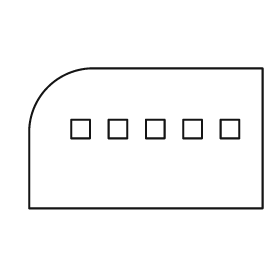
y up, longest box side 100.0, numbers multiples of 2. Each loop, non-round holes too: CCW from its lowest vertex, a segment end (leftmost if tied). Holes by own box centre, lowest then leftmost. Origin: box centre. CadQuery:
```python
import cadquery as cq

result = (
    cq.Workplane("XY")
    .moveTo(-50.0, -30.0)
    .lineTo(50.0, -30.0)
    .lineTo(50.0, 30.0)
    .lineTo(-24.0, 30.0)
    .threePointArc((-42.0, 22.0), (-50.0, 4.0))
    .close()
    .moveTo(-32.0, 0.0)
    .lineTo(-24.0, 0.0)
    .lineTo(-24.0, 8.0)
    .lineTo(-32.0, 8.0)
    .close()
    .moveTo(-16.0, 0.0)
    .lineTo(-8.0, 0.0)
    .lineTo(-8.0, 8.0)
    .lineTo(-16.0, 8.0)
    .close()
    .moveTo(0.0, 0.0)
    .lineTo(8.0, 0.0)
    .lineTo(8.0, 8.0)
    .lineTo(0.0, 8.0)
    .close()
    .moveTo(16.0, 0.0)
    .lineTo(24.0, 0.0)
    .lineTo(24.0, 8.0)
    .lineTo(16.0, 8.0)
    .close()
    .moveTo(32.0, 0.0)
    .lineTo(40.0, 0.0)
    .lineTo(40.0, 8.0)
    .lineTo(32.0, 8.0)
    .close()
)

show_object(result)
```